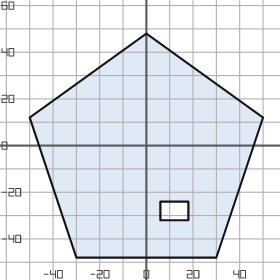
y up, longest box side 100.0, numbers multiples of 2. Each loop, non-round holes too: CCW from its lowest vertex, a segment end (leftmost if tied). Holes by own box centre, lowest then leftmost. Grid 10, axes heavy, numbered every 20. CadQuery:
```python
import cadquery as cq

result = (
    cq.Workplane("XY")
    .moveTo(-30.0, -48.0)
    .lineTo(30.0, -48.0)
    .lineTo(50.0, 12.0)
    .lineTo(0.0, 48.0)
    .lineTo(-50.0, 12.0)
    .close()
    .moveTo(6.0, -32.0)
    .lineTo(18.0, -32.0)
    .lineTo(18.0, -24.0)
    .lineTo(6.0, -24.0)
    .close()
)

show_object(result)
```